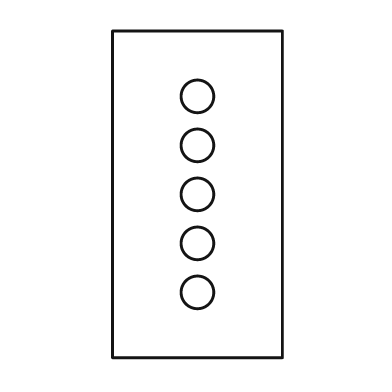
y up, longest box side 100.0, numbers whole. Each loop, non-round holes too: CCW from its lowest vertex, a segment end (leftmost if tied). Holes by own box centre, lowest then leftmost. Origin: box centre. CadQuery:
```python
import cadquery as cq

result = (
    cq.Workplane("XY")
    .moveTo(-26.0, -50.0)
    .lineTo(26.0, -50.0)
    .lineTo(26.0, 50.0)
    .lineTo(-26.0, 50.0)
    .close()
    .moveTo(0.0, -30.0)
    .circle(5.0)
    .moveTo(0.0, -15.0)
    .circle(5.0)
    .moveTo(0.0, 0.0)
    .circle(5.0)
    .moveTo(0.0, 15.0)
    .circle(5.0)
    .moveTo(0.0, 30.0)
    .circle(5.0)
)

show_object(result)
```